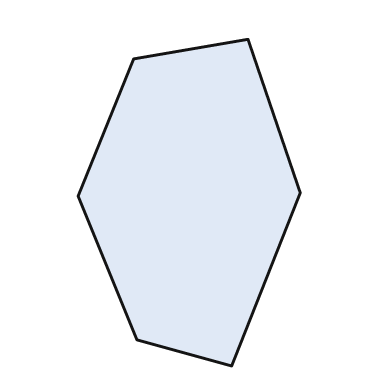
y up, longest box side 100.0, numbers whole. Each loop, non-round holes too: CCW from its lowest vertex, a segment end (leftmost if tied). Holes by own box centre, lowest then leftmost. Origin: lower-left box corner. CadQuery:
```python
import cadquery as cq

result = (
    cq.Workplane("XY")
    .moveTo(47.0, 0.0)
    .lineTo(68.0, 53.0)
    .lineTo(52.0, 100.0)
    .lineTo(17.0, 94.0)
    .lineTo(0.0, 52.0)
    .lineTo(18.0, 8.0)
    .close()
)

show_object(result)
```